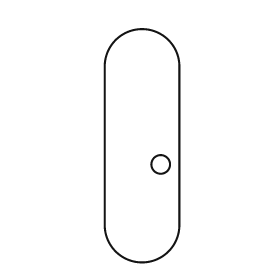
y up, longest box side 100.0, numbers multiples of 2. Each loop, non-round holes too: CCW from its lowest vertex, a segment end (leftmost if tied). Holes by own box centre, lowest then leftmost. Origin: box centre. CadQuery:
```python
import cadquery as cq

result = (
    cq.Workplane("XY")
    .moveTo(-16.0, -34.0)
    .threePointArc((0.0, -50.0), (16.0, -34.0))
    .lineTo(16.0, 34.0)
    .threePointArc((0.0, 50.0), (-16.0, 34.0))
    .close()
    .moveTo(8.0, -8.0)
    .circle(4.0)
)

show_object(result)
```